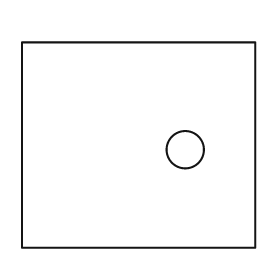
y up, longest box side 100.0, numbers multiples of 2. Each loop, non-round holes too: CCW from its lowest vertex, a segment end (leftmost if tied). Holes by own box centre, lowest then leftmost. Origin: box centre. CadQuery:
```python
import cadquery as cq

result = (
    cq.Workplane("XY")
    .moveTo(-50.0, -44.0)
    .lineTo(50.0, -44.0)
    .lineTo(50.0, 44.0)
    .lineTo(-50.0, 44.0)
    .close()
    .moveTo(20.0, -2.0)
    .circle(8.0)
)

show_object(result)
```